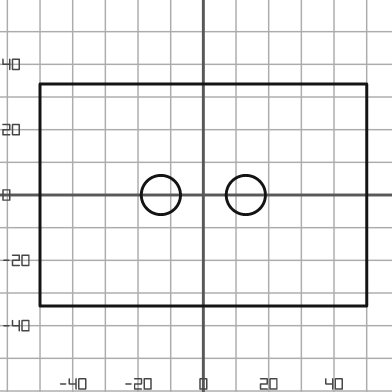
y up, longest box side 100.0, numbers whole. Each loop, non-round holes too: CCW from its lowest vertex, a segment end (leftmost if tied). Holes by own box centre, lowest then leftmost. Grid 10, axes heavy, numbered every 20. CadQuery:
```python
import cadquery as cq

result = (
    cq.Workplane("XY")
    .moveTo(-50.0, -34.0)
    .lineTo(50.0, -34.0)
    .lineTo(50.0, 34.0)
    .lineTo(-50.0, 34.0)
    .close()
    .moveTo(-13.0, 0.0)
    .circle(6.0)
    .moveTo(13.0, 0.0)
    .circle(6.0)
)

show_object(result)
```